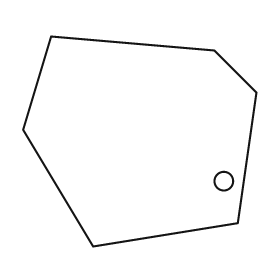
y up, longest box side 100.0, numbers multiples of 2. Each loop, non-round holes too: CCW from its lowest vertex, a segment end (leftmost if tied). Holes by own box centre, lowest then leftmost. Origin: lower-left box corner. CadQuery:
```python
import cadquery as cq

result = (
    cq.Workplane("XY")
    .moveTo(30.0, 0.0)
    .lineTo(92.0, 10.0)
    .lineTo(100.0, 66.0)
    .lineTo(82.0, 84.0)
    .lineTo(12.0, 90.0)
    .lineTo(0.0, 50.0)
    .close()
    .moveTo(86.0, 28.0)
    .circle(4.0)
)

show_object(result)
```